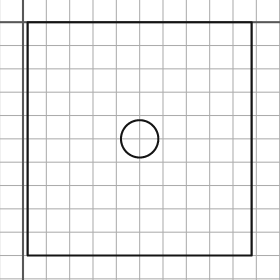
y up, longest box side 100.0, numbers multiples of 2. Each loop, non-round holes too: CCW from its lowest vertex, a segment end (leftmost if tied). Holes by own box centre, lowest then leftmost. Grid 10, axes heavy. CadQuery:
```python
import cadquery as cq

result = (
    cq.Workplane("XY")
    .moveTo(2.0, -100.0)
    .lineTo(98.0, -100.0)
    .lineTo(98.0, 0.0)
    .lineTo(2.0, 0.0)
    .close()
    .moveTo(50.0, -50.0)
    .circle(8.0)
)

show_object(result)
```